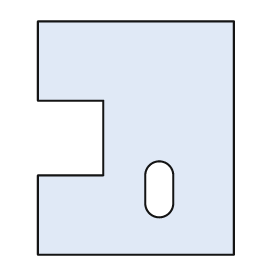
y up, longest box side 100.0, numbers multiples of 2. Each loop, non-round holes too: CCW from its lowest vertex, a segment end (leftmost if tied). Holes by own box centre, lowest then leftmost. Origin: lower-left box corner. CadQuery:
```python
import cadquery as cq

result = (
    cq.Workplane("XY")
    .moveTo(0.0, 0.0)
    .lineTo(84.0, 0.0)
    .lineTo(84.0, 100.0)
    .lineTo(0.0, 100.0)
    .lineTo(0.0, 66.0)
    .lineTo(28.0, 66.0)
    .lineTo(28.0, 34.0)
    .lineTo(0.0, 34.0)
    .close()
    .moveTo(46.0, 22.0)
    .threePointArc((52.0, 16.0), (58.0, 22.0))
    .lineTo(58.0, 34.0)
    .threePointArc((52.0, 40.0), (46.0, 34.0))
    .close()
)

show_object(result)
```